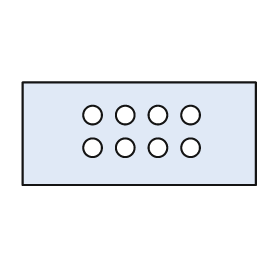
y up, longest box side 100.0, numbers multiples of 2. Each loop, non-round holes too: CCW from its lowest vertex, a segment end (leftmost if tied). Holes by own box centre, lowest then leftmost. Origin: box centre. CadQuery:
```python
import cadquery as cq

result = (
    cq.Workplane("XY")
    .moveTo(-50.0, -22.0)
    .lineTo(50.0, -22.0)
    .lineTo(50.0, 22.0)
    .lineTo(-50.0, 22.0)
    .close()
    .moveTo(-20.0, -6.0)
    .circle(4.0)
    .moveTo(-6.0, -6.0)
    .circle(4.0)
    .moveTo(8.0, -6.0)
    .circle(4.0)
    .moveTo(22.0, -6.0)
    .circle(4.0)
    .moveTo(-20.0, 8.0)
    .circle(4.0)
    .moveTo(-6.0, 8.0)
    .circle(4.0)
    .moveTo(8.0, 8.0)
    .circle(4.0)
    .moveTo(22.0, 8.0)
    .circle(4.0)
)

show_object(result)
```